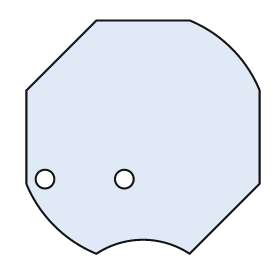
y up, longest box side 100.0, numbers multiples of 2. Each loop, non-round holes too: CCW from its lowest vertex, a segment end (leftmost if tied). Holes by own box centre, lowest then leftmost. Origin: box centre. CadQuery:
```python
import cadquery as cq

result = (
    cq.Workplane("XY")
    .moveTo(-20.0, -50.0)
    .threePointArc((0.0, -44.0), (20.0, -50.0))
    .lineTo(50.0, -20.0)
    .lineTo(50.0, 20.0)
    .threePointArc((38.0, 38.0), (20.0, 50.0))
    .lineTo(-20.0, 50.0)
    .lineTo(-50.0, 20.0)
    .lineTo(-50.0, -20.0)
    .threePointArc((-38.0, -38.0), (-20.0, -50.0))
    .close()
    .moveTo(-42.0, -18.0)
    .circle(4.0)
    .moveTo(-8.0, -18.0)
    .circle(4.0)
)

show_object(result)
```